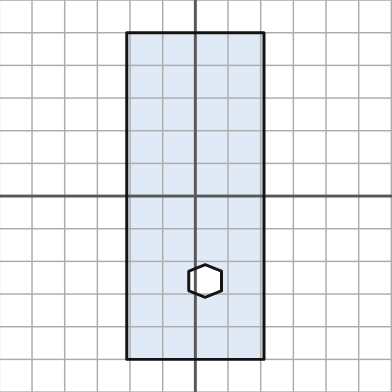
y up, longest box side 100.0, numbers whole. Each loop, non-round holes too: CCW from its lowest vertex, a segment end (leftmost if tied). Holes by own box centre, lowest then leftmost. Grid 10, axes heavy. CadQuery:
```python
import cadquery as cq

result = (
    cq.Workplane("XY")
    .moveTo(-21.0, -50.0)
    .lineTo(21.0, -50.0)
    .lineTo(21.0, 50.0)
    .lineTo(-21.0, 50.0)
    .close()
    .moveTo(3.0, -31.0)
    .lineTo(8.0, -29.0)
    .lineTo(8.0, -23.0)
    .lineTo(3.0, -21.0)
    .lineTo(-2.0, -23.0)
    .lineTo(-2.0, -29.0)
    .close()
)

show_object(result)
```